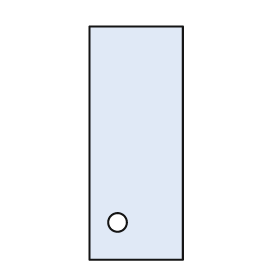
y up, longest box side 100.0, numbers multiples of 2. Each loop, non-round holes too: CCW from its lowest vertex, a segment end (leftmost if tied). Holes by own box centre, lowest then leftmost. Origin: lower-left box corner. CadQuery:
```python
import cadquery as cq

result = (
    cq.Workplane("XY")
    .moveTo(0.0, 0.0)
    .lineTo(40.0, 0.0)
    .lineTo(40.0, 100.0)
    .lineTo(0.0, 100.0)
    .close()
    .moveTo(12.0, 16.0)
    .circle(4.0)
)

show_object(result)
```